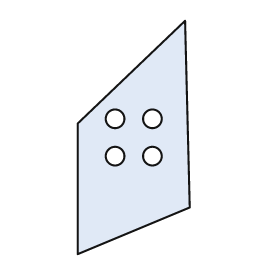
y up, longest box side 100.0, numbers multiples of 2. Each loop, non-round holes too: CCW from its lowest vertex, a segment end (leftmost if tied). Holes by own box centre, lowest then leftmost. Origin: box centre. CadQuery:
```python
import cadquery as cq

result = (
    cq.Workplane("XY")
    .moveTo(-24.0, -50.0)
    .lineTo(24.0, -30.0)
    .lineTo(22.0, 50.0)
    .lineTo(-24.0, 6.0)
    .close()
    .moveTo(-8.0, -8.0)
    .circle(4.0)
    .moveTo(8.0, -8.0)
    .circle(4.0)
    .moveTo(-8.0, 8.0)
    .circle(4.0)
    .moveTo(8.0, 8.0)
    .circle(4.0)
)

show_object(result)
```